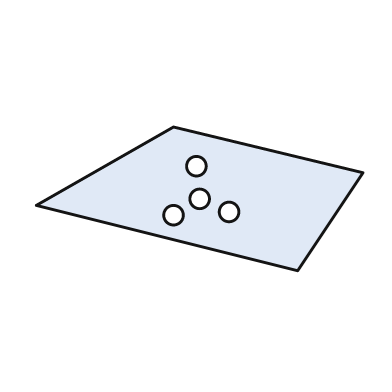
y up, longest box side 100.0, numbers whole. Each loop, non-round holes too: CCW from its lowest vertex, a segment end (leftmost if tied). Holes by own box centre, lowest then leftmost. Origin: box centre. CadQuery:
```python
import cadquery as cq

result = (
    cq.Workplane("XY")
    .moveTo(30.0, -22.0)
    .lineTo(50.0, 8.0)
    .lineTo(-8.0, 22.0)
    .lineTo(-50.0, -2.0)
    .close()
    .moveTo(-8.0, -5.0)
    .circle(3.0)
    .moveTo(9.0, -4.0)
    .circle(3.0)
    .moveTo(0.0, 0.0)
    .circle(3.0)
    .moveTo(-1.0, 10.0)
    .circle(3.0)
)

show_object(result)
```